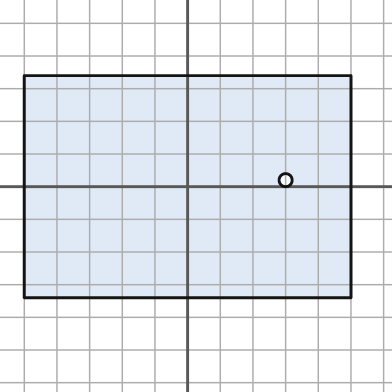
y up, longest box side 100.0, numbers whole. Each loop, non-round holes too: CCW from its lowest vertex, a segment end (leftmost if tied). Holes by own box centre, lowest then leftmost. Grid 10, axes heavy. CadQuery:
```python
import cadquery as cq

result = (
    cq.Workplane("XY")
    .moveTo(-50.0, -34.0)
    .lineTo(50.0, -34.0)
    .lineTo(50.0, 34.0)
    .lineTo(-50.0, 34.0)
    .close()
    .moveTo(30.0, 2.0)
    .circle(2.0)
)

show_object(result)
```